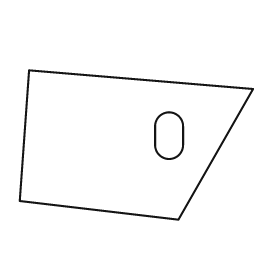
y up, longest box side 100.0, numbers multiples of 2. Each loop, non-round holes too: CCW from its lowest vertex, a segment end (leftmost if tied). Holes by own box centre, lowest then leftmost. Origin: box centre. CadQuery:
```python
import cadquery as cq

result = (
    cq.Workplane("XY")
    .moveTo(18.0, -32.0)
    .lineTo(50.0, 24.0)
    .lineTo(-46.0, 32.0)
    .lineTo(-50.0, -24.0)
    .close()
    .moveTo(8.0, 0.0)
    .threePointArc((14.0, -6.0), (20.0, 0.0))
    .lineTo(20.0, 8.0)
    .threePointArc((14.0, 14.0), (8.0, 8.0))
    .close()
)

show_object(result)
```